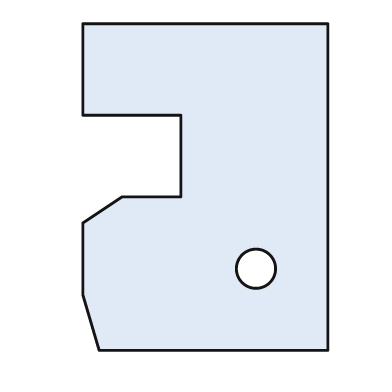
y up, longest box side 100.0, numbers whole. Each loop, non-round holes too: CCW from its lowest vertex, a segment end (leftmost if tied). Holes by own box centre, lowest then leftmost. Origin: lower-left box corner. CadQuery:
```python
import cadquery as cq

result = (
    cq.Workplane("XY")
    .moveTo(5.0, 0.0)
    .lineTo(75.0, 0.0)
    .lineTo(75.0, 100.0)
    .lineTo(0.0, 100.0)
    .lineTo(0.0, 72.0)
    .lineTo(30.0, 72.0)
    .lineTo(30.0, 47.0)
    .lineTo(12.0, 47.0)
    .lineTo(0.0, 39.0)
    .lineTo(0.0, 17.0)
    .close()
    .moveTo(53.0, 25.0)
    .circle(6.0)
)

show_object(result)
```